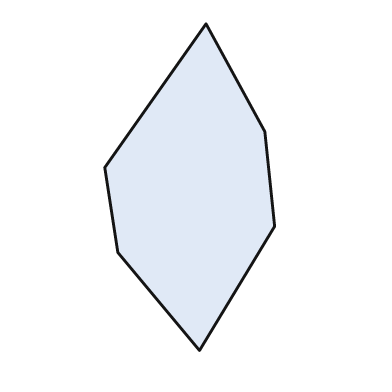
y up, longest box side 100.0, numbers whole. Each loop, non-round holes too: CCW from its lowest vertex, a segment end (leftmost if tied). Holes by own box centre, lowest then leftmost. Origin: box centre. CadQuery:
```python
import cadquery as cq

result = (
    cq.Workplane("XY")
    .moveTo(3.0, -50.0)
    .lineTo(26.0, -12.0)
    .lineTo(23.0, 17.0)
    .lineTo(5.0, 50.0)
    .lineTo(-26.0, 6.0)
    .lineTo(-22.0, -20.0)
    .close()
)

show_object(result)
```